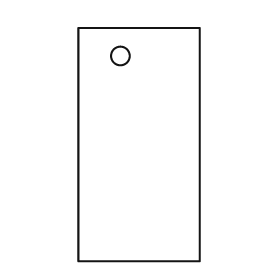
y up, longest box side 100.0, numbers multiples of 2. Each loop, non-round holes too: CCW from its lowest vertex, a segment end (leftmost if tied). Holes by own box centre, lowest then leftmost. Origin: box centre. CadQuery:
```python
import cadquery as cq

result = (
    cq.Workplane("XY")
    .moveTo(-26.0, -50.0)
    .lineTo(26.0, -50.0)
    .lineTo(26.0, 50.0)
    .lineTo(-26.0, 50.0)
    .close()
    .moveTo(-8.0, 38.0)
    .circle(4.0)
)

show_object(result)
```